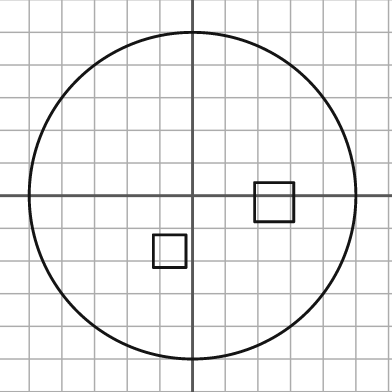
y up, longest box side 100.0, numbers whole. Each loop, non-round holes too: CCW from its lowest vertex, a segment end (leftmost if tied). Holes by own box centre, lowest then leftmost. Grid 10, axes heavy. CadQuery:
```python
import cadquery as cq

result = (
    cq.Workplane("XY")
    .moveTo(0.0, 0.0)
    .circle(50.0)
    .moveTo(-12.0, -22.0)
    .lineTo(-2.0, -22.0)
    .lineTo(-2.0, -12.0)
    .lineTo(-12.0, -12.0)
    .close()
    .moveTo(19.0, -8.0)
    .lineTo(31.0, -8.0)
    .lineTo(31.0, 4.0)
    .lineTo(19.0, 4.0)
    .close()
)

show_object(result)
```